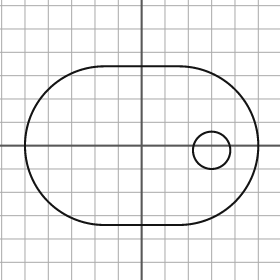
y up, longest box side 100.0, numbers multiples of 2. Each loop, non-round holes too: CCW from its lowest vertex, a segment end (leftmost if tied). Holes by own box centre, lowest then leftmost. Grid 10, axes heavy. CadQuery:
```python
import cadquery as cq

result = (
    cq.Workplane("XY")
    .moveTo(-16.0, -34.0)
    .lineTo(16.0, -34.0)
    .threePointArc((50.0, 0.0), (16.0, 34.0))
    .lineTo(-16.0, 34.0)
    .threePointArc((-50.0, 0.0), (-16.0, -34.0))
    .close()
    .moveTo(30.0, -2.0)
    .circle(8.0)
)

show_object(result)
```